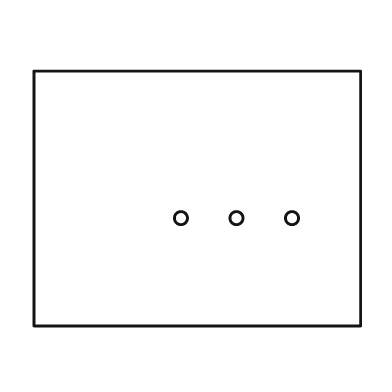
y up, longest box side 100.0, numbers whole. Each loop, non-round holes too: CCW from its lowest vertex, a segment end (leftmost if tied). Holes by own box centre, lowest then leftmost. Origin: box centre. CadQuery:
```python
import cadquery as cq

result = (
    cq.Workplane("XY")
    .moveTo(-50.0, -39.0)
    .lineTo(50.0, -39.0)
    .lineTo(50.0, 39.0)
    .lineTo(-50.0, 39.0)
    .close()
    .moveTo(-5.0, -6.0)
    .circle(2.0)
    .moveTo(12.0, -6.0)
    .circle(2.0)
    .moveTo(29.0, -6.0)
    .circle(2.0)
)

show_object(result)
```